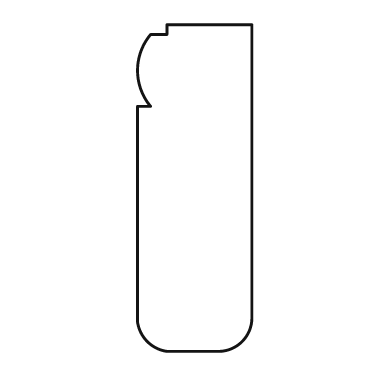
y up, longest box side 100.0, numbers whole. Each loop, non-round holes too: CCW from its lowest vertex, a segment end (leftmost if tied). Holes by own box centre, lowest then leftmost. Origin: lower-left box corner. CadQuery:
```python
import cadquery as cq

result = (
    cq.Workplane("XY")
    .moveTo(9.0, 0.0)
    .lineTo(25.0, 0.0)
    .threePointArc((32.0, 3.0), (35.0, 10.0))
    .lineTo(35.0, 100.0)
    .lineTo(9.0, 100.0)
    .lineTo(9.0, 97.0)
    .lineTo(4.0, 97.0)
    .threePointArc((0.0, 86.0), (4.0, 75.0))
    .lineTo(0.0, 75.0)
    .lineTo(0.0, 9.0)
    .threePointArc((3.0, 3.0), (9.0, 0.0))
    .close()
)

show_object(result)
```